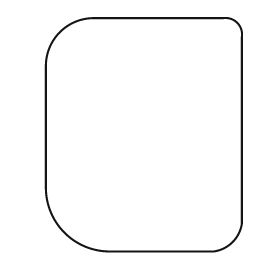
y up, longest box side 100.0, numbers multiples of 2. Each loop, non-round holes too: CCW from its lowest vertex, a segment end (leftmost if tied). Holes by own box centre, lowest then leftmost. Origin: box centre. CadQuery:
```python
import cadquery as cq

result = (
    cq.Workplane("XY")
    .moveTo(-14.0, -50.0)
    .lineTo(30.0, -50.0)
    .threePointArc((38.0, -46.0), (42.0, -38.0))
    .lineTo(42.0, 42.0)
    .threePointArc((40.0, 48.0), (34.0, 50.0))
    .lineTo(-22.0, 50.0)
    .threePointArc((-36.0, 44.0), (-42.0, 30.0))
    .lineTo(-42.0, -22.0)
    .threePointArc((-34.0, -42.0), (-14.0, -50.0))
    .close()
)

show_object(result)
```